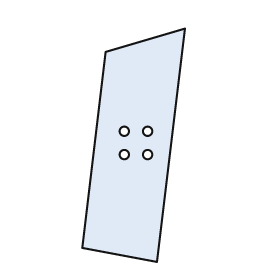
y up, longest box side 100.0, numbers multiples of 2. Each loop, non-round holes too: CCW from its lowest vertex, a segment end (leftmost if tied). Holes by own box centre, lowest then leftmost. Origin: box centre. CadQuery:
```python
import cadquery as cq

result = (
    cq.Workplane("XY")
    .moveTo(10.0, -50.0)
    .lineTo(22.0, 50.0)
    .lineTo(-12.0, 40.0)
    .lineTo(-22.0, -44.0)
    .close()
    .moveTo(-4.0, -4.0)
    .circle(2.0)
    .moveTo(6.0, -4.0)
    .circle(2.0)
    .moveTo(-4.0, 6.0)
    .circle(2.0)
    .moveTo(6.0, 6.0)
    .circle(2.0)
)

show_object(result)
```